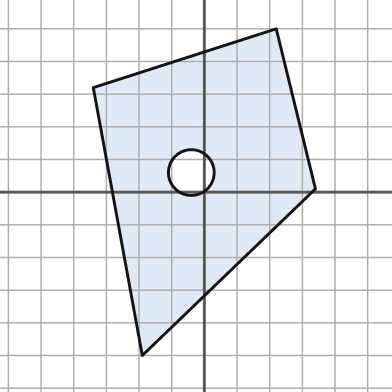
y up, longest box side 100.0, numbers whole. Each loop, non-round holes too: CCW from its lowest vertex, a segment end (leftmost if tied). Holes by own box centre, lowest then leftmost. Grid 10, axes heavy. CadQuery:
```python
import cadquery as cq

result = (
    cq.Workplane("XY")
    .moveTo(-19.0, -50.0)
    .lineTo(34.0, 1.0)
    .lineTo(22.0, 50.0)
    .lineTo(-34.0, 32.0)
    .close()
    .moveTo(-4.0, 6.0)
    .circle(7.0)
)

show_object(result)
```